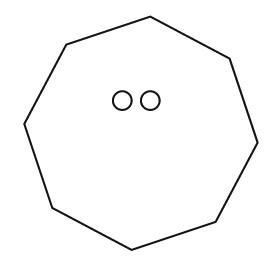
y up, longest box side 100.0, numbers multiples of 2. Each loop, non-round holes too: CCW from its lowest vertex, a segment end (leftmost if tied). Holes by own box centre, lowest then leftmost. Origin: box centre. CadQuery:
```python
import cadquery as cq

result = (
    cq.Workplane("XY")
    .moveTo(-4.0, -50.0)
    .lineTo(32.0, -38.0)
    .lineTo(50.0, -4.0)
    .lineTo(38.0, 32.0)
    .lineTo(4.0, 50.0)
    .lineTo(-32.0, 38.0)
    .lineTo(-50.0, 4.0)
    .lineTo(-38.0, -32.0)
    .close()
    .moveTo(-8.0, 14.0)
    .circle(4.0)
    .moveTo(4.0, 14.0)
    .circle(4.0)
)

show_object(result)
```